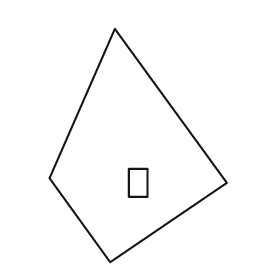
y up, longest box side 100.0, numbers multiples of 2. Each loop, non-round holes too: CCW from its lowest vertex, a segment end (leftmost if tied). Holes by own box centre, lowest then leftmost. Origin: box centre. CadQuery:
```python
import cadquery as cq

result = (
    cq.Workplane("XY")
    .moveTo(-12.0, -50.0)
    .lineTo(38.0, -16.0)
    .lineTo(-10.0, 50.0)
    .lineTo(-38.0, -14.0)
    .close()
    .moveTo(-4.0, -22.0)
    .lineTo(4.0, -22.0)
    .lineTo(4.0, -10.0)
    .lineTo(-4.0, -10.0)
    .close()
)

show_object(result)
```